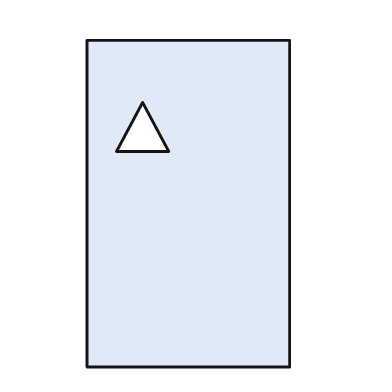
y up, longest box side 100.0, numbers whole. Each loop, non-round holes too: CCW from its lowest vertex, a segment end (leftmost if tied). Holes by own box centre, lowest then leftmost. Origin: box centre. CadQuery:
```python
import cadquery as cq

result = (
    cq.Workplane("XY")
    .moveTo(-31.0, -50.0)
    .lineTo(31.0, -50.0)
    .lineTo(31.0, 50.0)
    .lineTo(-31.0, 50.0)
    .close()
    .moveTo(-22.0, 16.0)
    .lineTo(-6.0, 16.0)
    .lineTo(-14.0, 31.0)
    .close()
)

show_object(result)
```